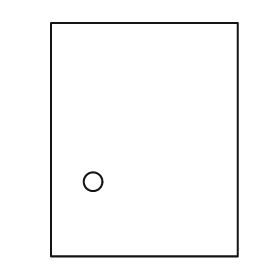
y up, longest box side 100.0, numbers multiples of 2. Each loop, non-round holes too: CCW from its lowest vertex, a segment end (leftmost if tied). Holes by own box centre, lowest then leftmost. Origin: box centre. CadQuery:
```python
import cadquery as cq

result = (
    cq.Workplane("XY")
    .moveTo(-40.0, -50.0)
    .lineTo(40.0, -50.0)
    .lineTo(40.0, 50.0)
    .lineTo(-40.0, 50.0)
    .close()
    .moveTo(-22.0, -18.0)
    .circle(4.0)
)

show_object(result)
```